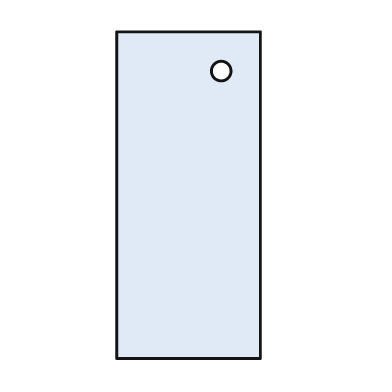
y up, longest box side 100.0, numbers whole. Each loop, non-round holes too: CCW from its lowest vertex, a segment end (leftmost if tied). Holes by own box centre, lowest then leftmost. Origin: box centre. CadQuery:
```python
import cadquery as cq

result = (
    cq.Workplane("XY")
    .moveTo(-22.0, -50.0)
    .lineTo(22.0, -50.0)
    .lineTo(22.0, 50.0)
    .lineTo(-22.0, 50.0)
    .close()
    .moveTo(10.0, 38.0)
    .circle(3.0)
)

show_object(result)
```